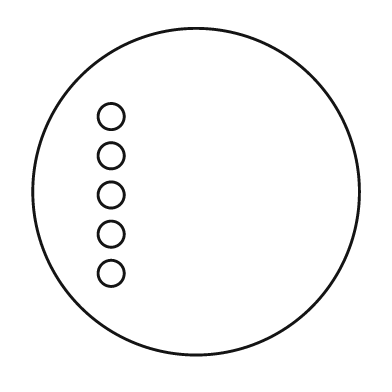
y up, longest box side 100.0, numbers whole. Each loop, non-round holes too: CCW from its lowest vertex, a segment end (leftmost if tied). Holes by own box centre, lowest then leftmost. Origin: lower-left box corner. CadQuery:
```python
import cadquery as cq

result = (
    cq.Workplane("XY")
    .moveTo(50.0, 50.0)
    .circle(50.0)
    .moveTo(24.0, 25.0)
    .circle(4.0)
    .moveTo(24.0, 37.0)
    .circle(4.0)
    .moveTo(24.0, 49.0)
    .circle(4.0)
    .moveTo(24.0, 61.0)
    .circle(4.0)
    .moveTo(24.0, 73.0)
    .circle(4.0)
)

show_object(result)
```